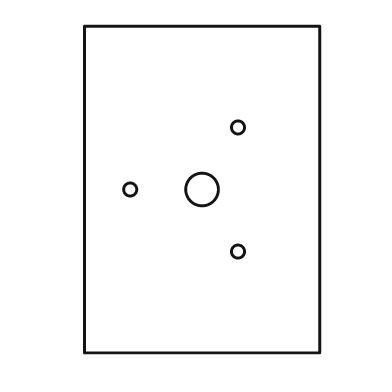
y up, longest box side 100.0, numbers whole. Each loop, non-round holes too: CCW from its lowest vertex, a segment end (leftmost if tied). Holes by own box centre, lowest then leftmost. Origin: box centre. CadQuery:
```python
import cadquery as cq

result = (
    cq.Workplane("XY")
    .moveTo(-36.0, -50.0)
    .lineTo(36.0, -50.0)
    .lineTo(36.0, 50.0)
    .lineTo(-36.0, 50.0)
    .close()
    .moveTo(11.0, -19.0)
    .circle(2.0)
    .moveTo(-22.0, 0.0)
    .circle(2.0)
    .moveTo(0.0, 0.0)
    .circle(5.0)
    .moveTo(11.0, 19.0)
    .circle(2.0)
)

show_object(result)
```